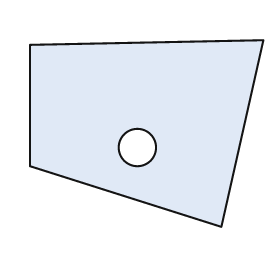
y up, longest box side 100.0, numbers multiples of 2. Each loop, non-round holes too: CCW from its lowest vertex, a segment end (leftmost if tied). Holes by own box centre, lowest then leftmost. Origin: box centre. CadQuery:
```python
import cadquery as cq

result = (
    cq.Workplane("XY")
    .moveTo(32.0, -40.0)
    .lineTo(50.0, 40.0)
    .lineTo(-50.0, 38.0)
    .lineTo(-50.0, -14.0)
    .close()
    .moveTo(-4.0, -6.0)
    .circle(8.0)
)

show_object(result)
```